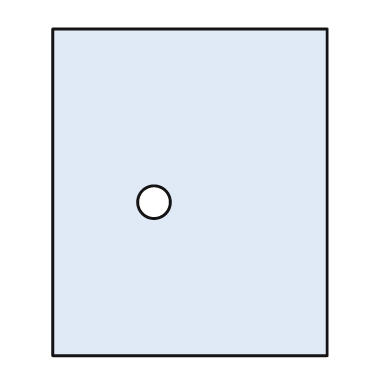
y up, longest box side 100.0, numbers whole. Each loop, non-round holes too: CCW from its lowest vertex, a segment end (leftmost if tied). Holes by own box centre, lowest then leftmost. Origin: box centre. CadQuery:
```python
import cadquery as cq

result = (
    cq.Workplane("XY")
    .moveTo(-42.0, -50.0)
    .lineTo(42.0, -50.0)
    .lineTo(42.0, 50.0)
    .lineTo(-42.0, 50.0)
    .close()
    .moveTo(-11.0, -3.0)
    .circle(5.0)
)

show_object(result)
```